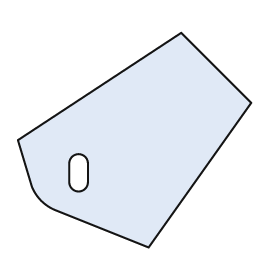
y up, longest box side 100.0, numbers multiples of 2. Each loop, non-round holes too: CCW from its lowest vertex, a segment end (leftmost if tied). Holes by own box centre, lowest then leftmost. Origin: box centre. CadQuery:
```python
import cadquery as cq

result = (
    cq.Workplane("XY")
    .moveTo(6.0, -46.0)
    .lineTo(50.0, 16.0)
    .lineTo(20.0, 46.0)
    .lineTo(-50.0, 0.0)
    .lineTo(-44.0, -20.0)
    .threePointArc((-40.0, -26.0), (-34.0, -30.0))
    .close()
    .moveTo(-28.0, -18.0)
    .threePointArc((-24.0, -22.0), (-20.0, -18.0))
    .lineTo(-20.0, -10.0)
    .threePointArc((-24.0, -6.0), (-28.0, -10.0))
    .close()
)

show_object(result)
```